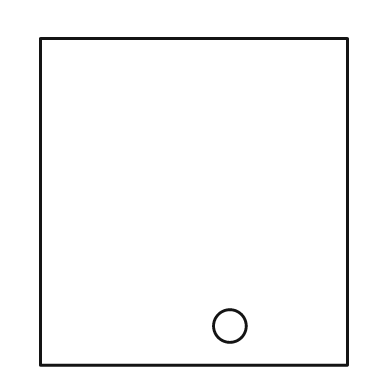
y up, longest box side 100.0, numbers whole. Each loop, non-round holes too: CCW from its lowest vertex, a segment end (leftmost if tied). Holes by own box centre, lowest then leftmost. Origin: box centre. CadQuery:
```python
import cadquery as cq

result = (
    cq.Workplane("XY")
    .moveTo(-47.0, -50.0)
    .lineTo(47.0, -50.0)
    .lineTo(47.0, 50.0)
    .lineTo(-47.0, 50.0)
    .close()
    .moveTo(11.0, -38.0)
    .circle(5.0)
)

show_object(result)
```